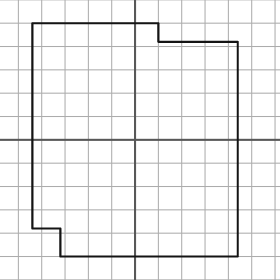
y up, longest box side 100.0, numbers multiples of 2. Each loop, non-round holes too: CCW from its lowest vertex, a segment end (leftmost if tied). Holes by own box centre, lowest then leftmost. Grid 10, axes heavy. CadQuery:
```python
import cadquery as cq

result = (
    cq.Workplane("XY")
    .moveTo(-32.0, -50.0)
    .lineTo(44.0, -50.0)
    .lineTo(44.0, 42.0)
    .lineTo(10.0, 42.0)
    .lineTo(10.0, 50.0)
    .lineTo(-44.0, 50.0)
    .lineTo(-44.0, -38.0)
    .lineTo(-32.0, -38.0)
    .close()
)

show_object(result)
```